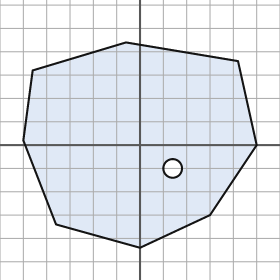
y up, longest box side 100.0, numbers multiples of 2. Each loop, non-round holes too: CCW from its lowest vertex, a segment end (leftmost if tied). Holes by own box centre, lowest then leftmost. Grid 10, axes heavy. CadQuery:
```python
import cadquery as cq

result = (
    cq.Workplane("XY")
    .moveTo(0.0, -44.0)
    .lineTo(30.0, -30.0)
    .lineTo(50.0, 0.0)
    .lineTo(42.0, 36.0)
    .lineTo(-6.0, 44.0)
    .lineTo(-46.0, 32.0)
    .lineTo(-50.0, 2.0)
    .lineTo(-36.0, -34.0)
    .close()
    .moveTo(14.0, -10.0)
    .circle(4.0)
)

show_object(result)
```